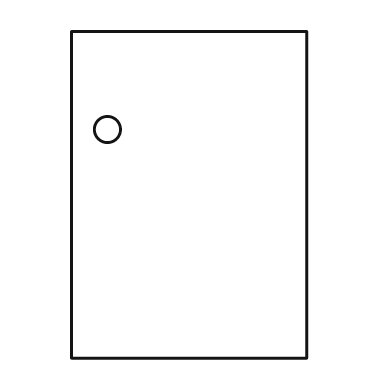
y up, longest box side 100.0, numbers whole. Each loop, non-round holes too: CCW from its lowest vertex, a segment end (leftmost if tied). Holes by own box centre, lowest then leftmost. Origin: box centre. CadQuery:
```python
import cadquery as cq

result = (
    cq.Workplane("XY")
    .moveTo(-36.0, -50.0)
    .lineTo(36.0, -50.0)
    .lineTo(36.0, 50.0)
    .lineTo(-36.0, 50.0)
    .close()
    .moveTo(-25.0, 20.0)
    .circle(4.0)
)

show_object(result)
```